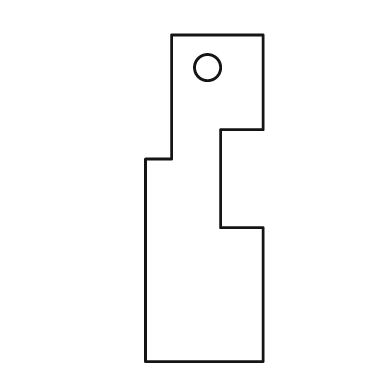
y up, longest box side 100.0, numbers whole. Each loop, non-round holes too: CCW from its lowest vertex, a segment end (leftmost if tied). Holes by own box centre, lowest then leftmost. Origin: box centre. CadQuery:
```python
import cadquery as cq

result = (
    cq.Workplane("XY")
    .moveTo(-18.0, -50.0)
    .lineTo(18.0, -50.0)
    .lineTo(18.0, -9.0)
    .lineTo(5.0, -9.0)
    .lineTo(5.0, 21.0)
    .lineTo(18.0, 21.0)
    .lineTo(18.0, 50.0)
    .lineTo(-10.0, 50.0)
    .lineTo(-10.0, 12.0)
    .lineTo(-18.0, 12.0)
    .close()
    .moveTo(1.0, 40.0)
    .circle(4.0)
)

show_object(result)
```